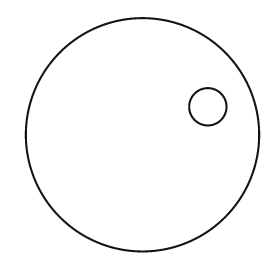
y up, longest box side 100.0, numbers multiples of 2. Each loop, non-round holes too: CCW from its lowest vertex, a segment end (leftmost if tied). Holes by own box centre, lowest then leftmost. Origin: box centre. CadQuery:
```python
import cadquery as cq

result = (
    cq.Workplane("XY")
    .moveTo(0.0, 0.0)
    .circle(50.0)
    .moveTo(28.0, 12.0)
    .circle(8.0)
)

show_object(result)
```